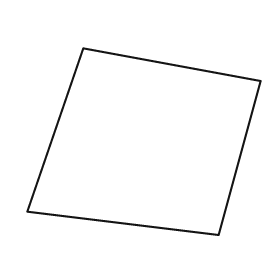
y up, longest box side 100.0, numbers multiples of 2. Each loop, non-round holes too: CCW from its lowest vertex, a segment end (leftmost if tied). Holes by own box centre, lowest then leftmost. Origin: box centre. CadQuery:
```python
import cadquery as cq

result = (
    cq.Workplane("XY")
    .moveTo(32.0, -40.0)
    .lineTo(50.0, 26.0)
    .lineTo(-26.0, 40.0)
    .lineTo(-50.0, -30.0)
    .close()
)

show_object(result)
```